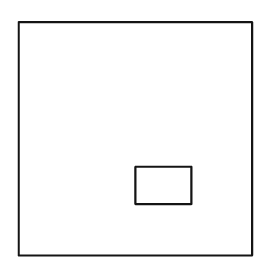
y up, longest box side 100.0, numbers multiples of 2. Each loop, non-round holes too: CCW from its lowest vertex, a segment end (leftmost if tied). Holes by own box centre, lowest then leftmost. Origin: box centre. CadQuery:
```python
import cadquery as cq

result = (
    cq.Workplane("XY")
    .moveTo(-50.0, -50.0)
    .lineTo(50.0, -50.0)
    .lineTo(50.0, 50.0)
    .lineTo(-50.0, 50.0)
    .close()
    .moveTo(0.0, -28.0)
    .lineTo(24.0, -28.0)
    .lineTo(24.0, -12.0)
    .lineTo(0.0, -12.0)
    .close()
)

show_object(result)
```